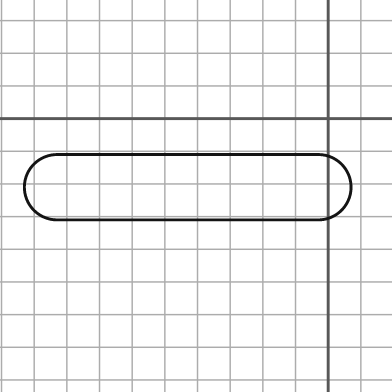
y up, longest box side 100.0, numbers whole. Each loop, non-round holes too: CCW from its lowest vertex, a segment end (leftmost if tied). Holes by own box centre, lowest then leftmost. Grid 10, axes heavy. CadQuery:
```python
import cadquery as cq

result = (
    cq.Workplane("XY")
    .moveTo(-83.0, -31.0)
    .lineTo(-3.0, -31.0)
    .threePointArc((7.0, -21.0), (-3.0, -11.0))
    .lineTo(-83.0, -11.0)
    .threePointArc((-93.0, -21.0), (-83.0, -31.0))
    .close()
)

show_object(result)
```